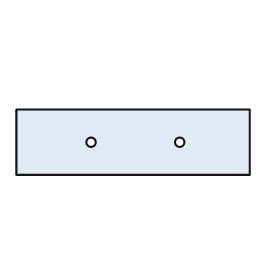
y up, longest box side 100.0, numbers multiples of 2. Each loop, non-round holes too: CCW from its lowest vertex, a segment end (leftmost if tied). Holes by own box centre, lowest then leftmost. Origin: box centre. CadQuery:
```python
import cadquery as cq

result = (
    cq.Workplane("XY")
    .moveTo(-50.0, -14.0)
    .lineTo(50.0, -14.0)
    .lineTo(50.0, 14.0)
    .lineTo(-50.0, 14.0)
    .close()
    .moveTo(-18.0, 0.0)
    .circle(2.0)
    .moveTo(20.0, 0.0)
    .circle(2.0)
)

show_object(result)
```